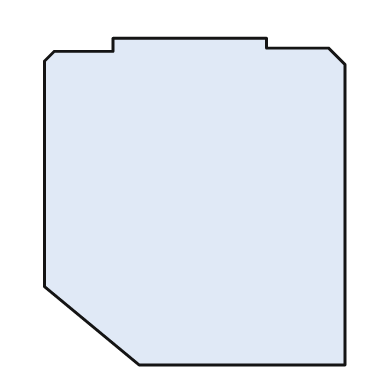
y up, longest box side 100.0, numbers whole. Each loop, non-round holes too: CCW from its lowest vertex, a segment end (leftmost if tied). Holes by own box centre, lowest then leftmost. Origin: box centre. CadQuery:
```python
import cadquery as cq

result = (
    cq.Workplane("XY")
    .moveTo(-17.0, -50.0)
    .lineTo(46.0, -50.0)
    .lineTo(46.0, 42.0)
    .lineTo(41.0, 47.0)
    .lineTo(22.0, 47.0)
    .lineTo(22.0, 50.0)
    .lineTo(-25.0, 50.0)
    .lineTo(-25.0, 46.0)
    .lineTo(-43.0, 46.0)
    .lineTo(-46.0, 43.0)
    .lineTo(-46.0, -26.0)
    .close()
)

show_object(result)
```